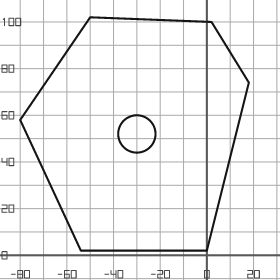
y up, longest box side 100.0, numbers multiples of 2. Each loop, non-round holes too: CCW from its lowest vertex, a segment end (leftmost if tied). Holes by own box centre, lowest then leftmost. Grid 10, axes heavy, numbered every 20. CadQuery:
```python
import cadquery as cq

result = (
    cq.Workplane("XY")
    .moveTo(-54.0, 2.0)
    .lineTo(0.0, 2.0)
    .lineTo(18.0, 74.0)
    .lineTo(2.0, 100.0)
    .lineTo(-50.0, 102.0)
    .lineTo(-80.0, 58.0)
    .close()
    .moveTo(-30.0, 52.0)
    .circle(8.0)
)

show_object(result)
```